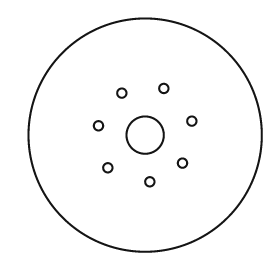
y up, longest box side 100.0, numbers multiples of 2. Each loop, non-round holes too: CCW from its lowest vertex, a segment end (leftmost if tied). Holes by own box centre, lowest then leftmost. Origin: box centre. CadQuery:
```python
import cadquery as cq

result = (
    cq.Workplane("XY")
    .moveTo(0.0, 0.0)
    .circle(50.0)
    .moveTo(2.0, -20.0)
    .circle(2.0)
    .moveTo(-16.0, -14.0)
    .circle(2.0)
    .moveTo(16.0, -12.0)
    .circle(2.0)
    .moveTo(0.0, 0.0)
    .circle(8.0)
    .moveTo(-20.0, 4.0)
    .circle(2.0)
    .moveTo(20.0, 6.0)
    .circle(2.0)
    .moveTo(-10.0, 18.0)
    .circle(2.0)
    .moveTo(8.0, 20.0)
    .circle(2.0)
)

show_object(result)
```